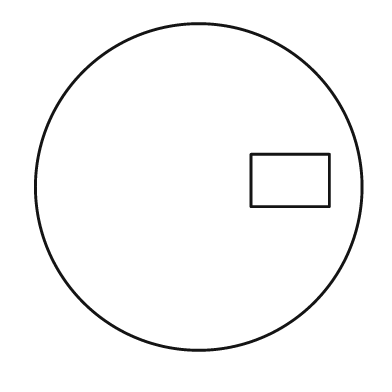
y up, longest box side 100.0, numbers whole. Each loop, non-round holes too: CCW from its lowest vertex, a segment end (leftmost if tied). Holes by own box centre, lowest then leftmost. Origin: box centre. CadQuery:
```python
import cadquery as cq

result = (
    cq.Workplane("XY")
    .moveTo(0.0, 0.0)
    .circle(50.0)
    .moveTo(16.0, -6.0)
    .lineTo(40.0, -6.0)
    .lineTo(40.0, 10.0)
    .lineTo(16.0, 10.0)
    .close()
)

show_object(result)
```